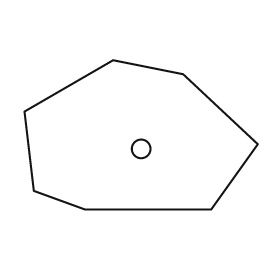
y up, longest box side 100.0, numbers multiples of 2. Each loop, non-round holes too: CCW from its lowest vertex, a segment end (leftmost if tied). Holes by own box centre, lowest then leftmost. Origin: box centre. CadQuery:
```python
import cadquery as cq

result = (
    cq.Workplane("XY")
    .moveTo(-24.0, -32.0)
    .lineTo(30.0, -32.0)
    .lineTo(50.0, -4.0)
    .lineTo(18.0, 26.0)
    .lineTo(-12.0, 32.0)
    .lineTo(-50.0, 10.0)
    .lineTo(-46.0, -24.0)
    .close()
    .moveTo(0.0, -6.0)
    .circle(4.0)
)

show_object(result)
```